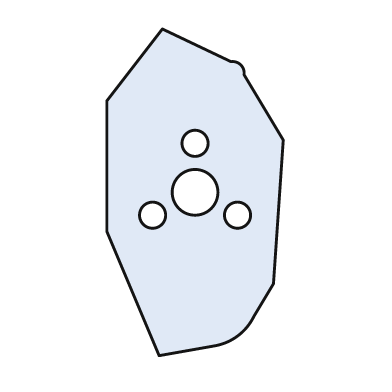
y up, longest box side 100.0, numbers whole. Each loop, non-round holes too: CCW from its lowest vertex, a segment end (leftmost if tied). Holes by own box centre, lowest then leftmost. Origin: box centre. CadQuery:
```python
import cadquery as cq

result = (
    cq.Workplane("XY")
    .moveTo(-11.0, -50.0)
    .lineTo(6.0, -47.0)
    .threePointArc((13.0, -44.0), (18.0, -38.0))
    .lineTo(24.0, -28.0)
    .lineTo(27.0, 16.0)
    .lineTo(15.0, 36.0)
    .threePointArc((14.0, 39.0), (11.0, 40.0))
    .lineTo(-10.0, 50.0)
    .lineTo(-27.0, 28.0)
    .lineTo(-27.0, -12.0)
    .close()
    .moveTo(-13.0, -7.0)
    .circle(4.0)
    .moveTo(13.0, -7.0)
    .circle(4.0)
    .moveTo(0.0, 0.0)
    .circle(7.0)
    .moveTo(0.0, 15.0)
    .circle(4.0)
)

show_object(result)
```